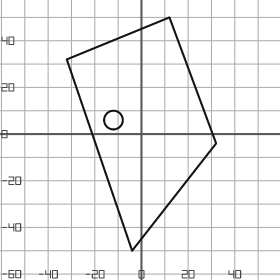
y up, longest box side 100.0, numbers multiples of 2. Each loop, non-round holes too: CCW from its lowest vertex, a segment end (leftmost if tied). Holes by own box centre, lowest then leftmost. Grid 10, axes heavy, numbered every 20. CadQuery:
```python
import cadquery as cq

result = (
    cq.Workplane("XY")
    .moveTo(-4.0, -50.0)
    .lineTo(32.0, -4.0)
    .lineTo(12.0, 50.0)
    .lineTo(-32.0, 32.0)
    .close()
    .moveTo(-12.0, 6.0)
    .circle(4.0)
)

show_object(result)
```